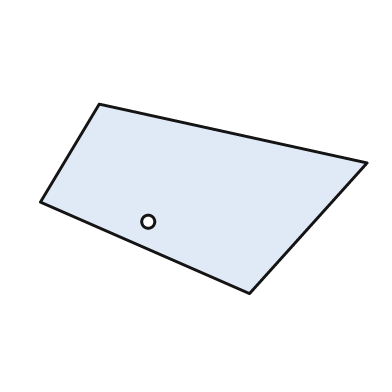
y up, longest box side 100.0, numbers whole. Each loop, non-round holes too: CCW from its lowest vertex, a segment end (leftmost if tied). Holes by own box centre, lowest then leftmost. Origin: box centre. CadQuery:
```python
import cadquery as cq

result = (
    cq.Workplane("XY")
    .moveTo(14.0, -29.0)
    .lineTo(50.0, 11.0)
    .lineTo(-32.0, 29.0)
    .lineTo(-50.0, -1.0)
    .close()
    .moveTo(-17.0, -7.0)
    .circle(2.0)
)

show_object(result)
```